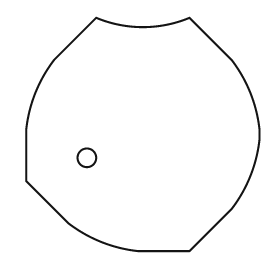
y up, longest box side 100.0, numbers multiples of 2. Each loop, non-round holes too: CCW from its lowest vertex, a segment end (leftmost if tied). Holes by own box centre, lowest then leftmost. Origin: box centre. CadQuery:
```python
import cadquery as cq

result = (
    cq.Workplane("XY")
    .moveTo(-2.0, -50.0)
    .lineTo(20.0, -50.0)
    .lineTo(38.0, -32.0)
    .threePointArc((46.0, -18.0), (50.0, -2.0))
    .lineTo(50.0, 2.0)
    .threePointArc((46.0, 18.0), (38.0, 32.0))
    .lineTo(20.0, 50.0)
    .threePointArc((0.0, 46.0), (-20.0, 50.0))
    .lineTo(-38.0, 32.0)
    .threePointArc((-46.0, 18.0), (-50.0, 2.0))
    .lineTo(-50.0, -20.0)
    .lineTo(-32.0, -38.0)
    .threePointArc((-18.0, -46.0), (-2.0, -50.0))
    .close()
    .moveTo(-24.0, -10.0)
    .circle(4.0)
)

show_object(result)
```